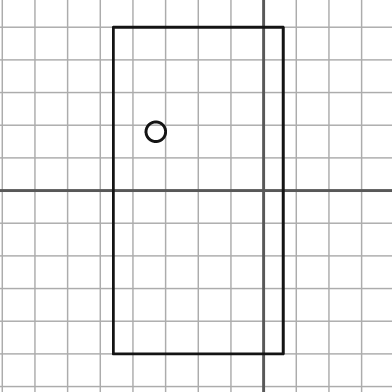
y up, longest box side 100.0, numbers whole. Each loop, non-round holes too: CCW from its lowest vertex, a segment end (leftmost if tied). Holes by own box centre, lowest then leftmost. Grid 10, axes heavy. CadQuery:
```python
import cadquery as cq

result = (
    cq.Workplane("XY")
    .moveTo(-46.0, -50.0)
    .lineTo(6.0, -50.0)
    .lineTo(6.0, 50.0)
    .lineTo(-46.0, 50.0)
    .close()
    .moveTo(-33.0, 18.0)
    .circle(3.0)
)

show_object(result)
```